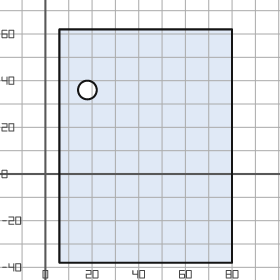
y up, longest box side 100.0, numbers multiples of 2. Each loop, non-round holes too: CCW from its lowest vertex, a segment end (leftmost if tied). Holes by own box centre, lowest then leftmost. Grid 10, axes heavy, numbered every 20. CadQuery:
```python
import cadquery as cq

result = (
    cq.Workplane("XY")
    .moveTo(6.0, -38.0)
    .lineTo(80.0, -38.0)
    .lineTo(80.0, 62.0)
    .lineTo(6.0, 62.0)
    .close()
    .moveTo(18.0, 36.0)
    .circle(4.0)
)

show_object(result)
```